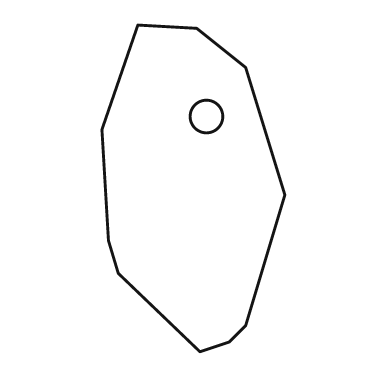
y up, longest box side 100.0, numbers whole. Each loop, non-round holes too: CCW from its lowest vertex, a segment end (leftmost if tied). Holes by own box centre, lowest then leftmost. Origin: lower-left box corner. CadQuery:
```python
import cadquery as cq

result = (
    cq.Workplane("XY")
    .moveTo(30.0, 0.0)
    .lineTo(39.0, 3.0)
    .lineTo(44.0, 8.0)
    .lineTo(56.0, 48.0)
    .lineTo(44.0, 87.0)
    .lineTo(29.0, 99.0)
    .lineTo(11.0, 100.0)
    .lineTo(0.0, 68.0)
    .lineTo(2.0, 34.0)
    .lineTo(5.0, 24.0)
    .close()
    .moveTo(32.0, 72.0)
    .circle(5.0)
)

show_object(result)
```